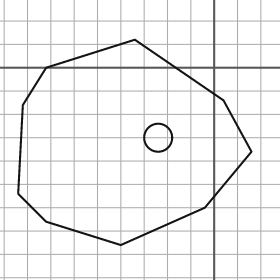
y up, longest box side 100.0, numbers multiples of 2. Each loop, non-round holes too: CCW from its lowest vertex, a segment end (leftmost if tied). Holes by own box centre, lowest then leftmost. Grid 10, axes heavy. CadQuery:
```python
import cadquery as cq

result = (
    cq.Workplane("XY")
    .moveTo(-40.0, -76.0)
    .lineTo(-4.0, -60.0)
    .lineTo(16.0, -36.0)
    .lineTo(4.0, -14.0)
    .lineTo(-34.0, 12.0)
    .lineTo(-72.0, 0.0)
    .lineTo(-82.0, -16.0)
    .lineTo(-84.0, -54.0)
    .lineTo(-72.0, -66.0)
    .close()
    .moveTo(-24.0, -30.0)
    .circle(6.0)
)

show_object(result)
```